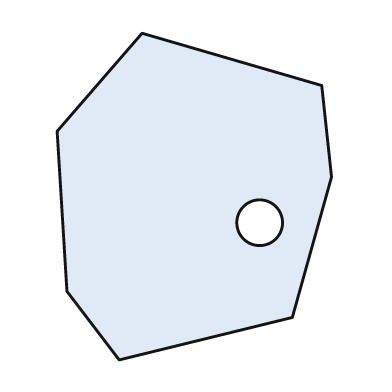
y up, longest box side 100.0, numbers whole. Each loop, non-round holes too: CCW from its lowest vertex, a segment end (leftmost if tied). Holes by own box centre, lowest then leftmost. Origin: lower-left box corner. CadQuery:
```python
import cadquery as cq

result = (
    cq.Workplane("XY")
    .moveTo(19.0, 0.0)
    .lineTo(72.0, 13.0)
    .lineTo(84.0, 56.0)
    .lineTo(81.0, 84.0)
    .lineTo(26.0, 100.0)
    .lineTo(0.0, 70.0)
    .lineTo(3.0, 21.0)
    .close()
    .moveTo(62.0, 42.0)
    .circle(7.0)
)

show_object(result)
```